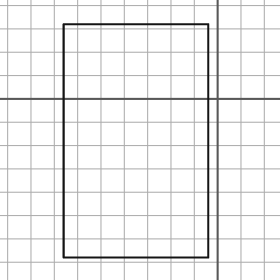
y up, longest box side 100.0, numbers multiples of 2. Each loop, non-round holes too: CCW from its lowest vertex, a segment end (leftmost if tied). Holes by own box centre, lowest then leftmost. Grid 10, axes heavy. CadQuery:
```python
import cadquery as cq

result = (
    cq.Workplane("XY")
    .moveTo(-66.0, -68.0)
    .lineTo(-4.0, -68.0)
    .lineTo(-4.0, 32.0)
    .lineTo(-66.0, 32.0)
    .close()
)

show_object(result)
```